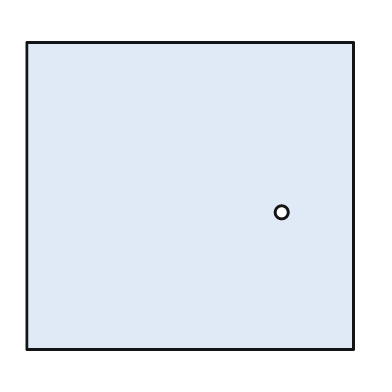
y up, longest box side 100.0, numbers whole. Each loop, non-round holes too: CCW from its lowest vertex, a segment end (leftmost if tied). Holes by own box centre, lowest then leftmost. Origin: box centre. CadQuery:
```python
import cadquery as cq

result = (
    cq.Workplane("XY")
    .moveTo(-50.0, -47.0)
    .lineTo(50.0, -47.0)
    .lineTo(50.0, 47.0)
    .lineTo(-50.0, 47.0)
    .close()
    .moveTo(28.0, -5.0)
    .circle(2.0)
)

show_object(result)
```